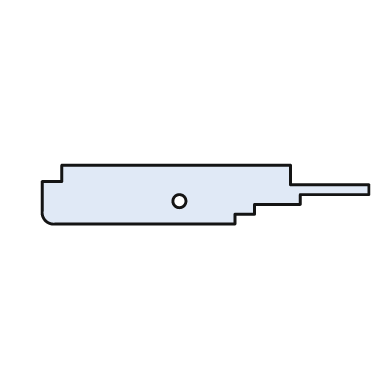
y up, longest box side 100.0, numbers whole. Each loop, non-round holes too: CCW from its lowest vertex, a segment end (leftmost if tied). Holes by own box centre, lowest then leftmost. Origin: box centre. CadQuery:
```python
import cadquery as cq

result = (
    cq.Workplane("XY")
    .moveTo(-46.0, -9.0)
    .lineTo(9.0, -9.0)
    .lineTo(9.0, -6.0)
    .lineTo(15.0, -6.0)
    .lineTo(15.0, -3.0)
    .lineTo(29.0, -3.0)
    .lineTo(29.0, 0.0)
    .lineTo(50.0, 0.0)
    .lineTo(50.0, 3.0)
    .lineTo(26.0, 3.0)
    .lineTo(26.0, 9.0)
    .lineTo(-44.0, 9.0)
    .lineTo(-44.0, 4.0)
    .lineTo(-50.0, 4.0)
    .lineTo(-50.0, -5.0)
    .threePointArc((-49.0, -8.0), (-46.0, -9.0))
    .close()
    .moveTo(-8.0, -2.0)
    .circle(2.0)
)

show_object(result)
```